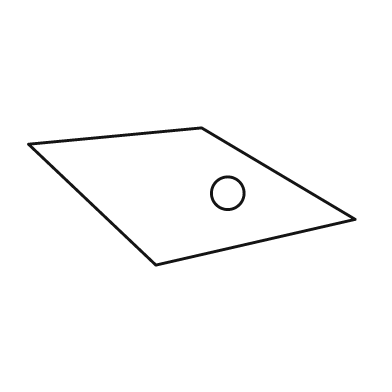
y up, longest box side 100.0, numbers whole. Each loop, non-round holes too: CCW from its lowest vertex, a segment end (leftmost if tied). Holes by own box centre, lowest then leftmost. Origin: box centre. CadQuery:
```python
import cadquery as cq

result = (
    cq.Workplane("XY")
    .moveTo(-11.0, -21.0)
    .lineTo(50.0, -7.0)
    .lineTo(3.0, 21.0)
    .lineTo(-50.0, 16.0)
    .close()
    .moveTo(11.0, 1.0)
    .circle(5.0)
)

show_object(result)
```